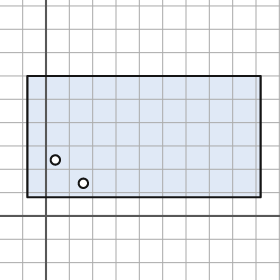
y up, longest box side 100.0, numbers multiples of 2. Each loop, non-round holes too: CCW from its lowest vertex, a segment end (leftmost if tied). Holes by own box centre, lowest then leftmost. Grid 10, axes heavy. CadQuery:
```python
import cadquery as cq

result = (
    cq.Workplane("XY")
    .moveTo(-8.0, 8.0)
    .lineTo(92.0, 8.0)
    .lineTo(92.0, 60.0)
    .lineTo(-8.0, 60.0)
    .close()
    .moveTo(16.0, 14.0)
    .circle(2.0)
    .moveTo(4.0, 24.0)
    .circle(2.0)
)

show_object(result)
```